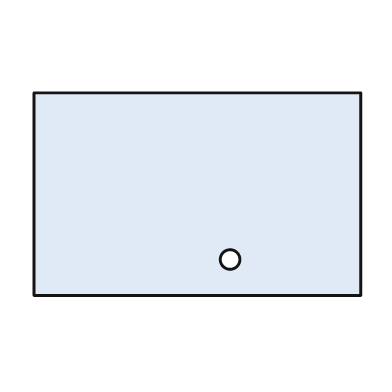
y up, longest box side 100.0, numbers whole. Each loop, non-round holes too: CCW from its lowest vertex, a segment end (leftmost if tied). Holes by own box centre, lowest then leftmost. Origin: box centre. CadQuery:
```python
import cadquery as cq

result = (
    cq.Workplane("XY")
    .moveTo(-50.0, -31.0)
    .lineTo(50.0, -31.0)
    .lineTo(50.0, 31.0)
    .lineTo(-50.0, 31.0)
    .close()
    .moveTo(10.0, -20.0)
    .circle(3.0)
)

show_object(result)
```